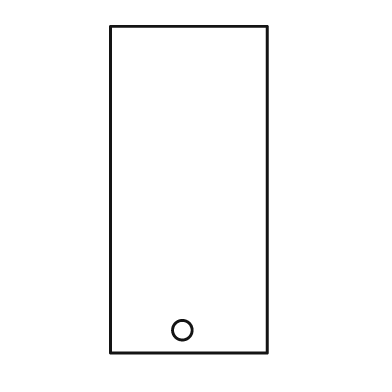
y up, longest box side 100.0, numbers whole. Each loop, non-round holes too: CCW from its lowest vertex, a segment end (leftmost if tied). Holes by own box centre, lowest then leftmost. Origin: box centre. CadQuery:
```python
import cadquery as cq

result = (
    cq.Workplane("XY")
    .moveTo(-24.0, -50.0)
    .lineTo(24.0, -50.0)
    .lineTo(24.0, 50.0)
    .lineTo(-24.0, 50.0)
    .close()
    .moveTo(-2.0, -43.0)
    .circle(3.0)
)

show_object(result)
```